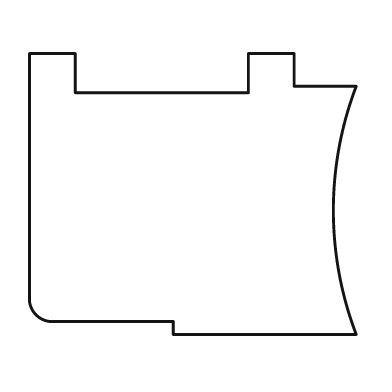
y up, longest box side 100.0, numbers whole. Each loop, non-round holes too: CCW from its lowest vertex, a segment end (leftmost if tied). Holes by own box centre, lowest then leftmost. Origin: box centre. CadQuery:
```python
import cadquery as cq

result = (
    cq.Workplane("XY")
    .moveTo(-6.0, -43.0)
    .lineTo(50.0, -43.0)
    .threePointArc((43.0, -5.0), (50.0, 33.0))
    .lineTo(31.0, 33.0)
    .lineTo(31.0, 43.0)
    .lineTo(17.0, 43.0)
    .lineTo(17.0, 31.0)
    .lineTo(-36.0, 31.0)
    .lineTo(-36.0, 43.0)
    .lineTo(-50.0, 43.0)
    .lineTo(-50.0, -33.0)
    .threePointArc((-48.0, -37.0), (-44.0, -39.0))
    .lineTo(-6.0, -39.0)
    .close()
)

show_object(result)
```